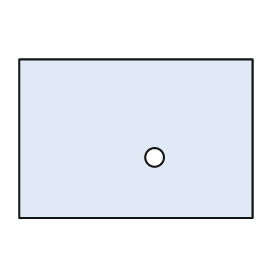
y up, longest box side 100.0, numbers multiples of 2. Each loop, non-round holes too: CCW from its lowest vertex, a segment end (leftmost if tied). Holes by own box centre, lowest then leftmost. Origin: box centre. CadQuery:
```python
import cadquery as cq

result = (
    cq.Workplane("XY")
    .moveTo(-50.0, -34.0)
    .lineTo(50.0, -34.0)
    .lineTo(50.0, 34.0)
    .lineTo(-50.0, 34.0)
    .close()
    .moveTo(8.0, -8.0)
    .circle(4.0)
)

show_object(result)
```